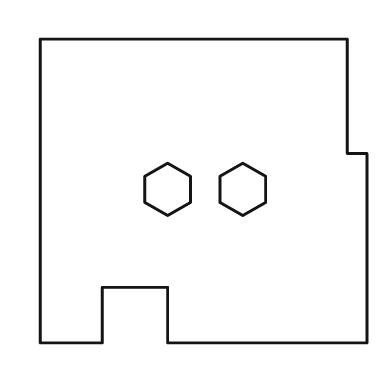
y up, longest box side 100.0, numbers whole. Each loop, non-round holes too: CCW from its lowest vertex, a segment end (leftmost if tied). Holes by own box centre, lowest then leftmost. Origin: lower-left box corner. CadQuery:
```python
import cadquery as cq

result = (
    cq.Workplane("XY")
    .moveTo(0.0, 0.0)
    .lineTo(19.0, 0.0)
    .lineTo(19.0, 17.0)
    .lineTo(39.0, 17.0)
    .lineTo(39.0, 0.0)
    .lineTo(100.0, 0.0)
    .lineTo(100.0, 58.0)
    .lineTo(94.0, 58.0)
    .lineTo(94.0, 93.0)
    .lineTo(0.0, 93.0)
    .close()
    .moveTo(39.0, 39.0)
    .lineTo(46.0, 43.0)
    .lineTo(46.0, 51.0)
    .lineTo(39.0, 55.0)
    .lineTo(32.0, 51.0)
    .lineTo(32.0, 43.0)
    .close()
    .moveTo(62.0, 39.0)
    .lineTo(69.0, 43.0)
    .lineTo(69.0, 51.0)
    .lineTo(62.0, 55.0)
    .lineTo(55.0, 51.0)
    .lineTo(55.0, 43.0)
    .close()
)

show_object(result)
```